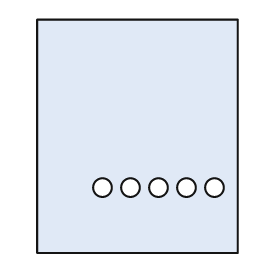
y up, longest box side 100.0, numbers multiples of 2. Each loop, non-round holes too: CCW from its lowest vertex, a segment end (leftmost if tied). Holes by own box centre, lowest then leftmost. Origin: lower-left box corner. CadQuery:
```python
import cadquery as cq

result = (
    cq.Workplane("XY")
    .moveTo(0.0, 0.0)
    .lineTo(86.0, 0.0)
    .lineTo(86.0, 100.0)
    .lineTo(0.0, 100.0)
    .close()
    .moveTo(28.0, 28.0)
    .circle(4.0)
    .moveTo(40.0, 28.0)
    .circle(4.0)
    .moveTo(52.0, 28.0)
    .circle(4.0)
    .moveTo(64.0, 28.0)
    .circle(4.0)
    .moveTo(76.0, 28.0)
    .circle(4.0)
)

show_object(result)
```